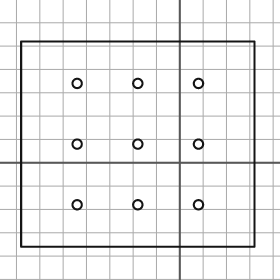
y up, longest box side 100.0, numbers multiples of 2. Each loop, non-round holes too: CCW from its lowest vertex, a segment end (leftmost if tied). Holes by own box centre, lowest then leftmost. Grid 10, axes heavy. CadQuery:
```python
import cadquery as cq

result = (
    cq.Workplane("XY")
    .moveTo(-68.0, -36.0)
    .lineTo(32.0, -36.0)
    .lineTo(32.0, 52.0)
    .lineTo(-68.0, 52.0)
    .close()
    .moveTo(-44.0, -18.0)
    .circle(2.0)
    .moveTo(-18.0, -18.0)
    .circle(2.0)
    .moveTo(8.0, -18.0)
    .circle(2.0)
    .moveTo(-44.0, 8.0)
    .circle(2.0)
    .moveTo(-18.0, 8.0)
    .circle(2.0)
    .moveTo(8.0, 8.0)
    .circle(2.0)
    .moveTo(-44.0, 34.0)
    .circle(2.0)
    .moveTo(-18.0, 34.0)
    .circle(2.0)
    .moveTo(8.0, 34.0)
    .circle(2.0)
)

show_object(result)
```